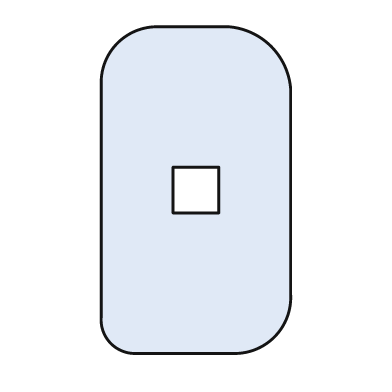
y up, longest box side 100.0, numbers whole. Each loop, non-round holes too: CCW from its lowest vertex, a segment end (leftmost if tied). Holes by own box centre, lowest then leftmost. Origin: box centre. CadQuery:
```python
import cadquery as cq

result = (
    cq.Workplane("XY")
    .moveTo(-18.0, -50.0)
    .lineTo(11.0, -50.0)
    .threePointArc((24.0, -45.0), (29.0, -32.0))
    .lineTo(29.0, 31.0)
    .threePointArc((23.0, 44.0), (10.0, 50.0))
    .lineTo(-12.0, 50.0)
    .threePointArc((-24.0, 45.0), (-29.0, 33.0))
    .lineTo(-29.0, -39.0)
    .threePointArc((-26.0, -47.0), (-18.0, -50.0))
    .close()
    .moveTo(-7.0, -7.0)
    .lineTo(7.0, -7.0)
    .lineTo(7.0, 7.0)
    .lineTo(-7.0, 7.0)
    .close()
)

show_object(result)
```